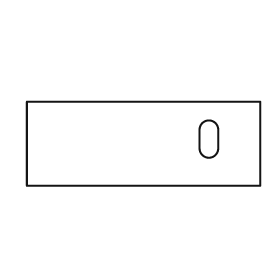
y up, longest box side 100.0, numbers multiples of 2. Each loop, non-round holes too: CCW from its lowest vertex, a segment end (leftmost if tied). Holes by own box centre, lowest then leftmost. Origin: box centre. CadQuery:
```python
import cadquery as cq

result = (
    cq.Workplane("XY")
    .moveTo(-50.0, -18.0)
    .lineTo(50.0, -18.0)
    .lineTo(50.0, 18.0)
    .lineTo(-50.0, 18.0)
    .close()
    .moveTo(24.0, -2.0)
    .threePointArc((28.0, -6.0), (32.0, -2.0))
    .lineTo(32.0, 6.0)
    .threePointArc((28.0, 10.0), (24.0, 6.0))
    .close()
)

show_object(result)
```